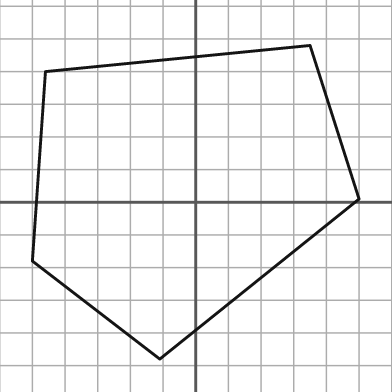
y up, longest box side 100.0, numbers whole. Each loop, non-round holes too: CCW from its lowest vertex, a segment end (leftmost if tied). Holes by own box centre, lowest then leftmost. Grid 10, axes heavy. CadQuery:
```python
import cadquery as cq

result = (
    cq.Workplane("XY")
    .moveTo(-11.0, -48.0)
    .lineTo(50.0, 1.0)
    .lineTo(35.0, 48.0)
    .lineTo(-46.0, 40.0)
    .lineTo(-50.0, -18.0)
    .close()
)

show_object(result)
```